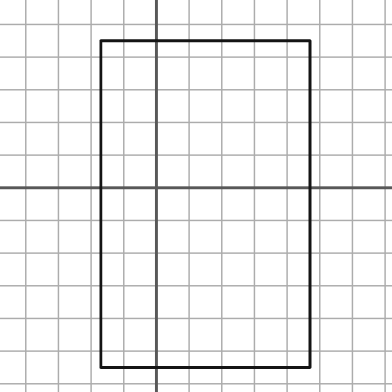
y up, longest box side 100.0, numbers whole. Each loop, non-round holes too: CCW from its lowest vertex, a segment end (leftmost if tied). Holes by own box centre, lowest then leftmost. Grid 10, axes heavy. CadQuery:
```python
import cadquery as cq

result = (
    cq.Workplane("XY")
    .moveTo(-17.0, -55.0)
    .lineTo(47.0, -55.0)
    .lineTo(47.0, 45.0)
    .lineTo(-17.0, 45.0)
    .close()
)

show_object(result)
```